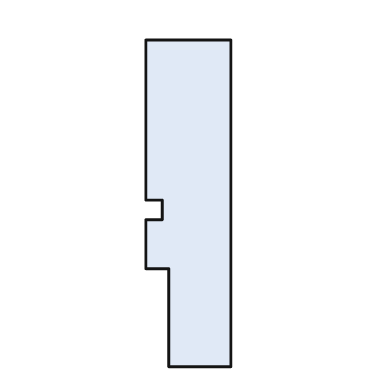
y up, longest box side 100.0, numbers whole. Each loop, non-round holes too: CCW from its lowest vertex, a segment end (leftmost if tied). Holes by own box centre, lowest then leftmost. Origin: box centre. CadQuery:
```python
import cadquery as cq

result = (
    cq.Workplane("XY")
    .moveTo(-6.0, -50.0)
    .lineTo(13.0, -50.0)
    .lineTo(13.0, 50.0)
    .lineTo(-13.0, 50.0)
    .lineTo(-13.0, 1.0)
    .lineTo(-8.0, 1.0)
    .lineTo(-8.0, -5.0)
    .lineTo(-13.0, -5.0)
    .lineTo(-13.0, -20.0)
    .lineTo(-6.0, -20.0)
    .close()
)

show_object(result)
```